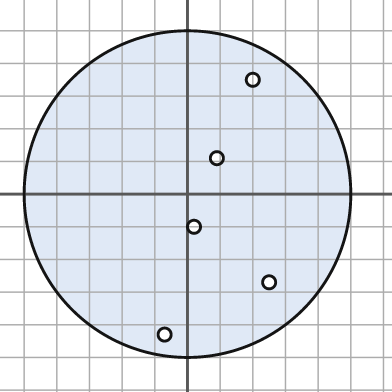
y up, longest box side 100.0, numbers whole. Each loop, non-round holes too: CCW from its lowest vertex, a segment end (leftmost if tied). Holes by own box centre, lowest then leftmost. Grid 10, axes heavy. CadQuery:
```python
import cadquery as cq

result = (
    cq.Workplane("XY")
    .moveTo(0.0, 0.0)
    .circle(50.0)
    .moveTo(-7.0, -43.0)
    .circle(2.0)
    .moveTo(25.0, -27.0)
    .circle(2.0)
    .moveTo(2.0, -10.0)
    .circle(2.0)
    .moveTo(9.0, 11.0)
    .circle(2.0)
    .moveTo(20.0, 35.0)
    .circle(2.0)
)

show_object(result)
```